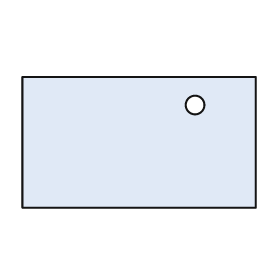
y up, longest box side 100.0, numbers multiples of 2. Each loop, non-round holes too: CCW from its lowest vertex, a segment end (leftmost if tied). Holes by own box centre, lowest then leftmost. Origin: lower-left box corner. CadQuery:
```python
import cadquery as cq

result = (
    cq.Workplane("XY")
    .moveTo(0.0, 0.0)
    .lineTo(100.0, 0.0)
    .lineTo(100.0, 56.0)
    .lineTo(0.0, 56.0)
    .close()
    .moveTo(74.0, 44.0)
    .circle(4.0)
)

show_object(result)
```